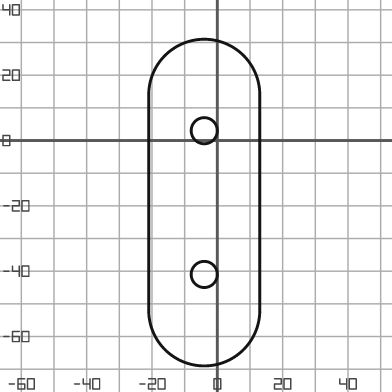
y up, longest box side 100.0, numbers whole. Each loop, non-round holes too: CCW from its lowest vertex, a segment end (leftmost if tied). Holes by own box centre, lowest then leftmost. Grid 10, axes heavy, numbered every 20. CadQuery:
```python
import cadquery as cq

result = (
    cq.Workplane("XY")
    .moveTo(-21.0, -52.0)
    .threePointArc((-4.0, -69.0), (13.0, -52.0))
    .lineTo(13.0, 14.0)
    .threePointArc((-4.0, 31.0), (-21.0, 14.0))
    .close()
    .moveTo(-4.0, -41.0)
    .circle(4.0)
    .moveTo(-4.0, 3.0)
    .circle(4.0)
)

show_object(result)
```